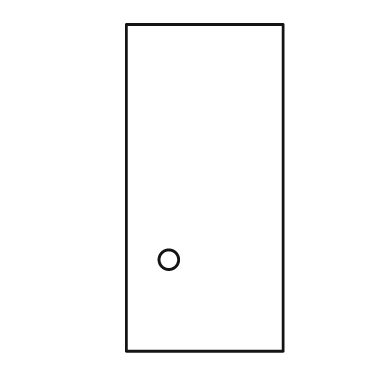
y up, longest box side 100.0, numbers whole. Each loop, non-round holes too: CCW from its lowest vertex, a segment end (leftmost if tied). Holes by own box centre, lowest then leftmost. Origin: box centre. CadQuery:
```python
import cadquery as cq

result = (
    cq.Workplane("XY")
    .moveTo(-24.0, -50.0)
    .lineTo(24.0, -50.0)
    .lineTo(24.0, 50.0)
    .lineTo(-24.0, 50.0)
    .close()
    .moveTo(-11.0, -22.0)
    .circle(3.0)
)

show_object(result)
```